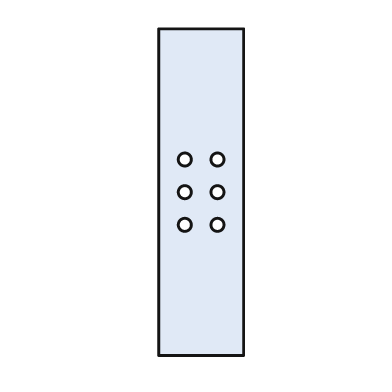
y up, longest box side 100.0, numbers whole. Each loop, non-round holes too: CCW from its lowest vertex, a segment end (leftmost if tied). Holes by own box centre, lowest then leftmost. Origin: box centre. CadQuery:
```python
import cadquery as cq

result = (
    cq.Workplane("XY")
    .moveTo(-13.0, -50.0)
    .lineTo(13.0, -50.0)
    .lineTo(13.0, 50.0)
    .lineTo(-13.0, 50.0)
    .close()
    .moveTo(-5.0, -10.0)
    .circle(2.0)
    .moveTo(5.0, -10.0)
    .circle(2.0)
    .moveTo(-5.0, 0.0)
    .circle(2.0)
    .moveTo(5.0, 0.0)
    .circle(2.0)
    .moveTo(-5.0, 10.0)
    .circle(2.0)
    .moveTo(5.0, 10.0)
    .circle(2.0)
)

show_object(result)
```